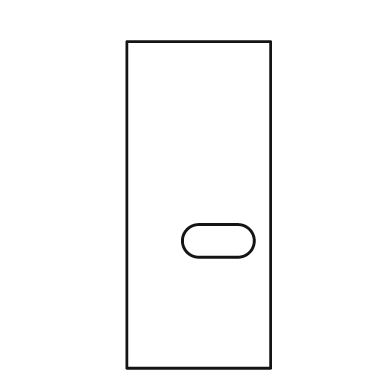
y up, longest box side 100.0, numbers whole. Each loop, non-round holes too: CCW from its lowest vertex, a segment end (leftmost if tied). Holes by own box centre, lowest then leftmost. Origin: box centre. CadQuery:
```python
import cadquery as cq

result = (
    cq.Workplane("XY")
    .moveTo(-22.0, -50.0)
    .lineTo(22.0, -50.0)
    .lineTo(22.0, 50.0)
    .lineTo(-22.0, 50.0)
    .close()
    .moveTo(0.0, -16.0)
    .lineTo(12.0, -16.0)
    .threePointArc((17.0, -11.0), (12.0, -6.0))
    .lineTo(0.0, -6.0)
    .threePointArc((-5.0, -11.0), (0.0, -16.0))
    .close()
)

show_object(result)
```